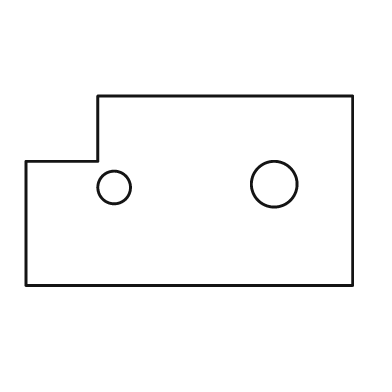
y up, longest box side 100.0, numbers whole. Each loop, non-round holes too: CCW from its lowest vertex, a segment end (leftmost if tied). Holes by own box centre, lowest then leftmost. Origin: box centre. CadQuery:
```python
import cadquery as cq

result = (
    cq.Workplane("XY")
    .moveTo(-50.0, -29.0)
    .lineTo(50.0, -29.0)
    .lineTo(50.0, 29.0)
    .lineTo(-28.0, 29.0)
    .lineTo(-28.0, 9.0)
    .lineTo(-50.0, 9.0)
    .close()
    .moveTo(-23.0, 1.0)
    .circle(5.0)
    .moveTo(26.0, 2.0)
    .circle(7.0)
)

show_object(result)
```